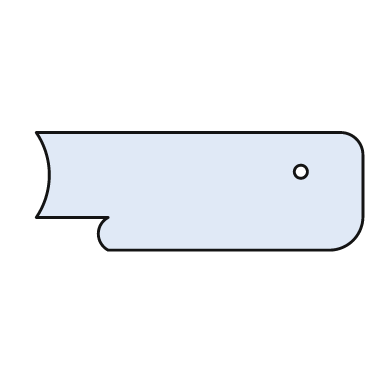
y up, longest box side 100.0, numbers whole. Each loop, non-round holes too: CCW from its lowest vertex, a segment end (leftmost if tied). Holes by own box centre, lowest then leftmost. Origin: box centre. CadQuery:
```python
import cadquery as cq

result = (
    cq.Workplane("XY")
    .moveTo(-28.0, -18.0)
    .lineTo(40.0, -18.0)
    .threePointArc((47.0, -15.0), (50.0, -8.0))
    .lineTo(50.0, 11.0)
    .threePointArc((48.0, 16.0), (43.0, 18.0))
    .lineTo(-50.0, 18.0)
    .threePointArc((-46.0, 5.0), (-50.0, -8.0))
    .lineTo(-28.0, -8.0)
    .threePointArc((-31.0, -13.0), (-28.0, -18.0))
    .close()
    .moveTo(31.0, 6.0)
    .circle(2.0)
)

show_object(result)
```